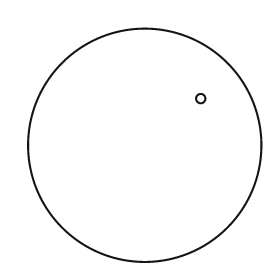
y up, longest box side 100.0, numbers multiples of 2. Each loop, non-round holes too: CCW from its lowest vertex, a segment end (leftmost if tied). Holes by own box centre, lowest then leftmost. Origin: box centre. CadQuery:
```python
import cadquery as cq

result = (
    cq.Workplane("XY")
    .moveTo(0.0, 0.0)
    .circle(50.0)
    .moveTo(24.0, 20.0)
    .circle(2.0)
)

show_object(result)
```